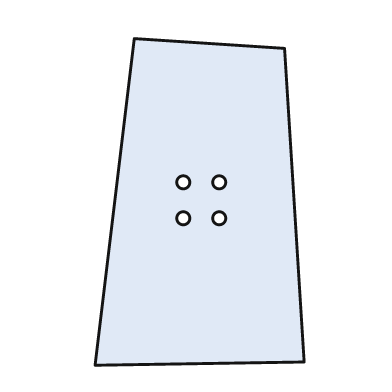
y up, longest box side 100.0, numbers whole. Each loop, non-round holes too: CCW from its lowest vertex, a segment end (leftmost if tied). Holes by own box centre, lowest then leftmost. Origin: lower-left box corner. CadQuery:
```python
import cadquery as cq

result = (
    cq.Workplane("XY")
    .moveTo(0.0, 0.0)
    .lineTo(64.0, 1.0)
    .lineTo(58.0, 97.0)
    .lineTo(12.0, 100.0)
    .close()
    .moveTo(27.0, 45.0)
    .circle(2.0)
    .moveTo(38.0, 45.0)
    .circle(2.0)
    .moveTo(27.0, 56.0)
    .circle(2.0)
    .moveTo(38.0, 56.0)
    .circle(2.0)
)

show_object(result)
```